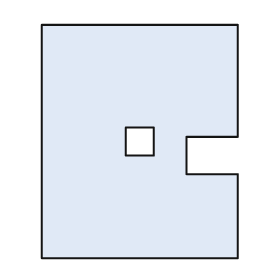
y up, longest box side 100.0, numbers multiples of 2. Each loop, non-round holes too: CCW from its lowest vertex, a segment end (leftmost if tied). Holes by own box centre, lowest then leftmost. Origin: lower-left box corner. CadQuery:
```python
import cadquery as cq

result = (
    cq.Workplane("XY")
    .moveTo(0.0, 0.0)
    .lineTo(84.0, 0.0)
    .lineTo(84.0, 36.0)
    .lineTo(62.0, 36.0)
    .lineTo(62.0, 52.0)
    .lineTo(84.0, 52.0)
    .lineTo(84.0, 100.0)
    .lineTo(0.0, 100.0)
    .close()
    .moveTo(36.0, 44.0)
    .lineTo(48.0, 44.0)
    .lineTo(48.0, 56.0)
    .lineTo(36.0, 56.0)
    .close()
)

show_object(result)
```